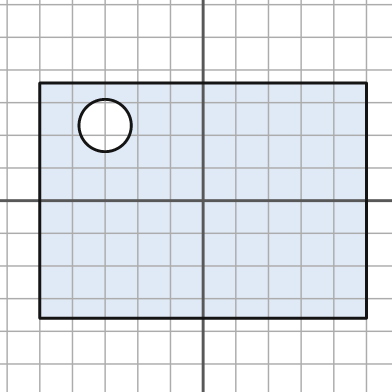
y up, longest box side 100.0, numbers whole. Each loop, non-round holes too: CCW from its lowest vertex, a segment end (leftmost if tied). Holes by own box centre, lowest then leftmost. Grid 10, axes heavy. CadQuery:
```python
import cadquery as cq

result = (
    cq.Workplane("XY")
    .moveTo(-50.0, -36.0)
    .lineTo(50.0, -36.0)
    .lineTo(50.0, 36.0)
    .lineTo(-50.0, 36.0)
    .close()
    .moveTo(-30.0, 23.0)
    .circle(8.0)
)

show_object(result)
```